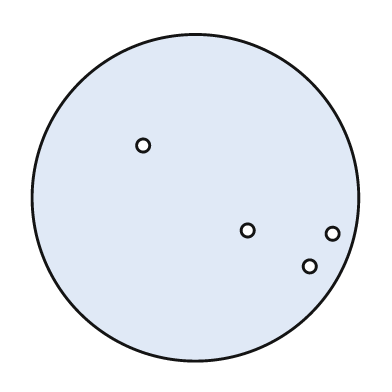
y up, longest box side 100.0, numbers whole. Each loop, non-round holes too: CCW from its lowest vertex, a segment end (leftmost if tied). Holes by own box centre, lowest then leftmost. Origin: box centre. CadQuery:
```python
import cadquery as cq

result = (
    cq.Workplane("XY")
    .moveTo(0.0, 0.0)
    .circle(50.0)
    .moveTo(35.0, -21.0)
    .circle(2.0)
    .moveTo(42.0, -11.0)
    .circle(2.0)
    .moveTo(16.0, -10.0)
    .circle(2.0)
    .moveTo(-16.0, 16.0)
    .circle(2.0)
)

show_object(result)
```